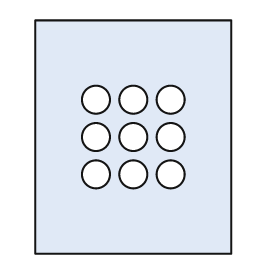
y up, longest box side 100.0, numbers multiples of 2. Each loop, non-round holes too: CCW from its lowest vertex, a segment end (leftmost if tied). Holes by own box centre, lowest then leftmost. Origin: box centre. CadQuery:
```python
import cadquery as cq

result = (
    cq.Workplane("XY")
    .moveTo(-42.0, -50.0)
    .lineTo(42.0, -50.0)
    .lineTo(42.0, 50.0)
    .lineTo(-42.0, 50.0)
    .close()
    .moveTo(-16.0, -16.0)
    .circle(6.0)
    .moveTo(0.0, -16.0)
    .circle(6.0)
    .moveTo(16.0, -16.0)
    .circle(6.0)
    .moveTo(-16.0, 0.0)
    .circle(6.0)
    .moveTo(0.0, 0.0)
    .circle(6.0)
    .moveTo(16.0, 0.0)
    .circle(6.0)
    .moveTo(-16.0, 16.0)
    .circle(6.0)
    .moveTo(0.0, 16.0)
    .circle(6.0)
    .moveTo(16.0, 16.0)
    .circle(6.0)
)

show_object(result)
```